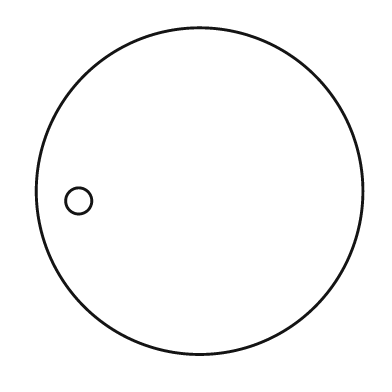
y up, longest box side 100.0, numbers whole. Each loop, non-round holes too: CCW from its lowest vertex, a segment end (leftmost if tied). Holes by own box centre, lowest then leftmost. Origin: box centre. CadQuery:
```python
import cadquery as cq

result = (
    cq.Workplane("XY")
    .moveTo(0.0, 0.0)
    .circle(50.0)
    .moveTo(-37.0, -3.0)
    .circle(4.0)
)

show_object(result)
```